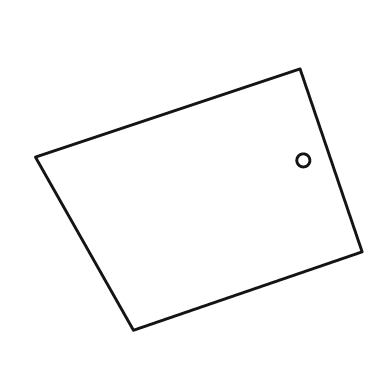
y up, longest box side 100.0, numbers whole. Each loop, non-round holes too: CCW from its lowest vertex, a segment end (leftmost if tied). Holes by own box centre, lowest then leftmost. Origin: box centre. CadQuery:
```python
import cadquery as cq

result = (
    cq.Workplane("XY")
    .moveTo(-20.0, -40.0)
    .lineTo(50.0, -16.0)
    .lineTo(31.0, 40.0)
    .lineTo(-50.0, 13.0)
    .close()
    .moveTo(32.0, 12.0)
    .circle(2.0)
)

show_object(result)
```